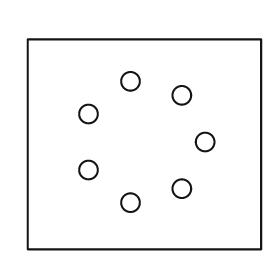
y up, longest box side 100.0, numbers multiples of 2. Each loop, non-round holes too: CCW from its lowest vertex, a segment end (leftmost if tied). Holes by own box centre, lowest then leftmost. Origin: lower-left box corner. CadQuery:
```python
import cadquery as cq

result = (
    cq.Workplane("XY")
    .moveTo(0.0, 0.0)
    .lineTo(100.0, 0.0)
    .lineTo(100.0, 90.0)
    .lineTo(0.0, 90.0)
    .close()
    .moveTo(44.0, 20.0)
    .circle(4.0)
    .moveTo(66.0, 26.0)
    .circle(4.0)
    .moveTo(26.0, 34.0)
    .circle(4.0)
    .moveTo(76.0, 46.0)
    .circle(4.0)
    .moveTo(26.0, 58.0)
    .circle(4.0)
    .moveTo(66.0, 66.0)
    .circle(4.0)
    .moveTo(44.0, 72.0)
    .circle(4.0)
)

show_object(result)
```